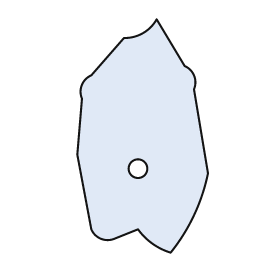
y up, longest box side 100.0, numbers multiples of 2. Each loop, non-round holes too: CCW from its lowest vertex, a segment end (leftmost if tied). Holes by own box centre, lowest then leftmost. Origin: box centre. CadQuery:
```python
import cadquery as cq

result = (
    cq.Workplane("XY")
    .moveTo(12.0, -50.0)
    .threePointArc((22.0, -34.0), (28.0, -16.0))
    .lineTo(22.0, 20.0)
    .threePointArc((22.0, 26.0), (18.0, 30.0))
    .lineTo(6.0, 50.0)
    .threePointArc((0.0, 44.0), (-8.0, 42.0))
    .lineTo(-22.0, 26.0)
    .threePointArc((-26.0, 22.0), (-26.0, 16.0))
    .lineTo(-28.0, -8.0)
    .lineTo(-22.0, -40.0)
    .threePointArc((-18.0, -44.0), (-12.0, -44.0))
    .lineTo(-2.0, -40.0)
    .threePointArc((4.0, -46.0), (12.0, -50.0))
    .close()
    .moveTo(-2.0, -14.0)
    .circle(4.0)
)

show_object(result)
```